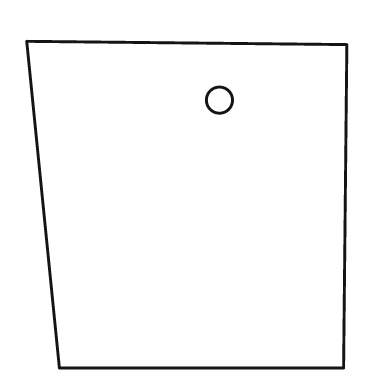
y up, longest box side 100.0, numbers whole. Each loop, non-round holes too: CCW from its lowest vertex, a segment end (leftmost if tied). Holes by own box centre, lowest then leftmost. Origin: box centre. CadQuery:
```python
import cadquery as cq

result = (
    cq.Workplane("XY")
    .moveTo(-39.0, -50.0)
    .lineTo(48.0, -50.0)
    .lineTo(49.0, 49.0)
    .lineTo(-49.0, 50.0)
    .close()
    .moveTo(10.0, 32.0)
    .circle(4.0)
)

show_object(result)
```